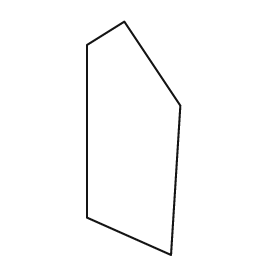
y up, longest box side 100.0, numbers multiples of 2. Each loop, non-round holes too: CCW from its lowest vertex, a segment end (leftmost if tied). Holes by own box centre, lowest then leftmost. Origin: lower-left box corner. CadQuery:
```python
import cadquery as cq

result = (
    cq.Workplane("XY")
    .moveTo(36.0, 0.0)
    .lineTo(40.0, 64.0)
    .lineTo(16.0, 100.0)
    .lineTo(0.0, 90.0)
    .lineTo(0.0, 16.0)
    .close()
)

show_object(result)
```